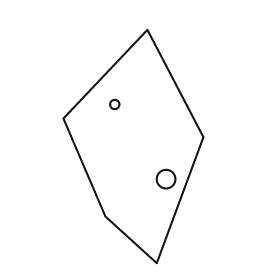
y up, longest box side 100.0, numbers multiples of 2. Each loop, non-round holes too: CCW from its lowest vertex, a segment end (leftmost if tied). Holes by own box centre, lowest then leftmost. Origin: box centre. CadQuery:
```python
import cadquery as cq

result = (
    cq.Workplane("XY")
    .moveTo(10.0, -50.0)
    .lineTo(30.0, 4.0)
    .lineTo(6.0, 50.0)
    .lineTo(-30.0, 12.0)
    .lineTo(-12.0, -30.0)
    .close()
    .moveTo(14.0, -14.0)
    .circle(4.0)
    .moveTo(-8.0, 18.0)
    .circle(2.0)
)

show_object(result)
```